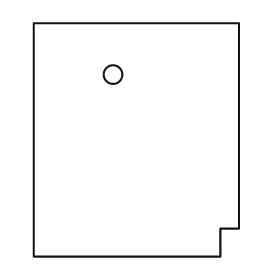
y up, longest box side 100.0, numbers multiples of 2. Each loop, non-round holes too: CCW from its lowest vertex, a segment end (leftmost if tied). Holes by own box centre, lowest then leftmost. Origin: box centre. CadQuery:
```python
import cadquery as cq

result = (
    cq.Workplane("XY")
    .moveTo(-44.0, -50.0)
    .lineTo(36.0, -50.0)
    .lineTo(36.0, -38.0)
    .lineTo(44.0, -38.0)
    .lineTo(44.0, 50.0)
    .lineTo(-44.0, 50.0)
    .close()
    .moveTo(-10.0, 28.0)
    .circle(4.0)
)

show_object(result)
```